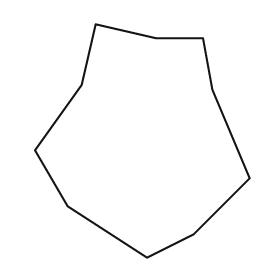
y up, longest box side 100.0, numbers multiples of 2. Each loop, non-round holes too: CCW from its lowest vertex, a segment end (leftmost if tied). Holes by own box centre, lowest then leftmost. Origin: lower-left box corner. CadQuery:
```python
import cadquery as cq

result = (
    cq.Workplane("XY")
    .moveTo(48.0, 0.0)
    .lineTo(68.0, 10.0)
    .lineTo(92.0, 34.0)
    .lineTo(76.0, 72.0)
    .lineTo(72.0, 94.0)
    .lineTo(52.0, 94.0)
    .lineTo(26.0, 100.0)
    .lineTo(20.0, 74.0)
    .lineTo(0.0, 46.0)
    .lineTo(14.0, 22.0)
    .close()
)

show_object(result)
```